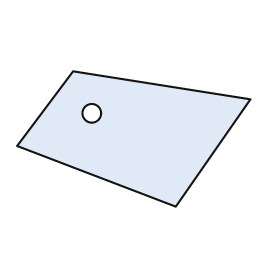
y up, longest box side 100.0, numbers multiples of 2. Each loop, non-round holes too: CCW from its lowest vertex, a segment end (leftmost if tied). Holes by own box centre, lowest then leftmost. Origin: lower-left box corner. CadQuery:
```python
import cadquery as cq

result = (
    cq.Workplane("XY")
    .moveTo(68.0, 0.0)
    .lineTo(100.0, 46.0)
    .lineTo(24.0, 58.0)
    .lineTo(0.0, 26.0)
    .close()
    .moveTo(32.0, 40.0)
    .circle(4.0)
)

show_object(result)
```